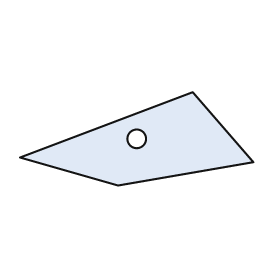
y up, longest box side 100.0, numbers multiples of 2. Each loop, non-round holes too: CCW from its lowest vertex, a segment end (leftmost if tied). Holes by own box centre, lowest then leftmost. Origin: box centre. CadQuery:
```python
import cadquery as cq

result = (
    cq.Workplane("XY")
    .moveTo(-8.0, -20.0)
    .lineTo(50.0, -10.0)
    .lineTo(24.0, 20.0)
    .lineTo(-50.0, -8.0)
    .close()
    .moveTo(0.0, 0.0)
    .circle(4.0)
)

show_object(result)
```